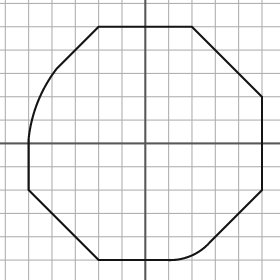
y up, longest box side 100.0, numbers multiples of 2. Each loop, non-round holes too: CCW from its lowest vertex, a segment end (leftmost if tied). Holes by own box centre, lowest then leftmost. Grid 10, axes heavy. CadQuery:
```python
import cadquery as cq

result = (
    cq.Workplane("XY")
    .moveTo(-20.0, -50.0)
    .lineTo(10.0, -50.0)
    .threePointArc((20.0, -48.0), (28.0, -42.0))
    .lineTo(50.0, -20.0)
    .lineTo(50.0, 20.0)
    .lineTo(20.0, 50.0)
    .lineTo(-20.0, 50.0)
    .lineTo(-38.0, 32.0)
    .threePointArc((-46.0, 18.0), (-50.0, 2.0))
    .lineTo(-50.0, -20.0)
    .close()
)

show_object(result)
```